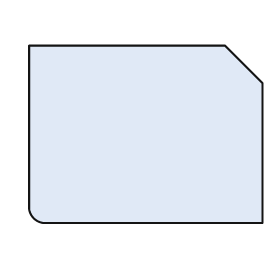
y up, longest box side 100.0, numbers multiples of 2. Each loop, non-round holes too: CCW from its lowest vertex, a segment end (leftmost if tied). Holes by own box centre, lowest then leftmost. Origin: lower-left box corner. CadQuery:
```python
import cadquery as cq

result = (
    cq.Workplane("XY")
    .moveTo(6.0, 0.0)
    .lineTo(100.0, 0.0)
    .lineTo(100.0, 60.0)
    .lineTo(84.0, 76.0)
    .lineTo(0.0, 76.0)
    .lineTo(0.0, 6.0)
    .threePointArc((2.0, 2.0), (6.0, 0.0))
    .close()
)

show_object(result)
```